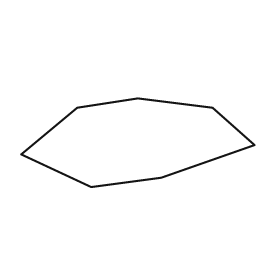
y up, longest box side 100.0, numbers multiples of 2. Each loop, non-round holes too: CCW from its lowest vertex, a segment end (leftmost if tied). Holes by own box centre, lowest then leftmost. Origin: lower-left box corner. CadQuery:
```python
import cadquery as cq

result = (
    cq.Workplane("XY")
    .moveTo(30.0, 0.0)
    .lineTo(60.0, 4.0)
    .lineTo(100.0, 18.0)
    .lineTo(82.0, 34.0)
    .lineTo(50.0, 38.0)
    .lineTo(24.0, 34.0)
    .lineTo(0.0, 14.0)
    .close()
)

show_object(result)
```